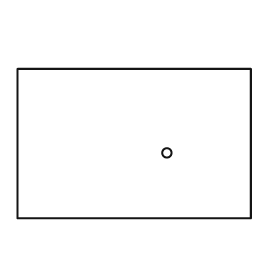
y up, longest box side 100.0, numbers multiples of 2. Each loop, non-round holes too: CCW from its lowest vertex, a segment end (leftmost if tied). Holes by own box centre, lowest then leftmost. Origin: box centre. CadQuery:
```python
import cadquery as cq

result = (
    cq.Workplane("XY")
    .moveTo(-50.0, -32.0)
    .lineTo(50.0, -32.0)
    .lineTo(50.0, 32.0)
    .lineTo(-50.0, 32.0)
    .close()
    .moveTo(14.0, -4.0)
    .circle(2.0)
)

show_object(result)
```